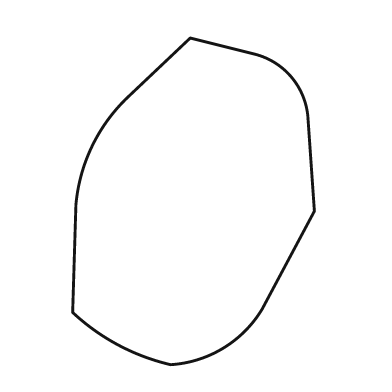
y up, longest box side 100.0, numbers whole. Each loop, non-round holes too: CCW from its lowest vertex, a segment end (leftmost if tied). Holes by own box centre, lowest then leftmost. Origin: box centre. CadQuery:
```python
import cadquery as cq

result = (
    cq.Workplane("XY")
    .moveTo(-7.0, -50.0)
    .threePointArc((9.0, -45.0), (21.0, -33.0))
    .lineTo(37.0, -3.0)
    .lineTo(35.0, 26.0)
    .threePointArc((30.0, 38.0), (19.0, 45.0))
    .lineTo(-1.0, 50.0)
    .lineTo(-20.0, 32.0)
    .threePointArc((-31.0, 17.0), (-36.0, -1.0))
    .lineTo(-37.0, -34.0)
    .threePointArc((-23.0, -44.0), (-7.0, -50.0))
    .close()
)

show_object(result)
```